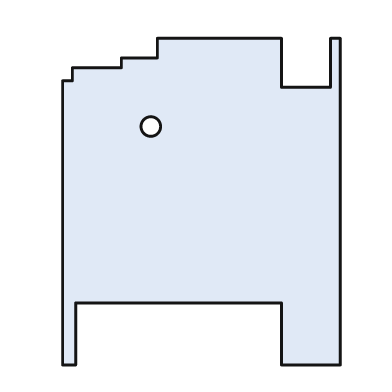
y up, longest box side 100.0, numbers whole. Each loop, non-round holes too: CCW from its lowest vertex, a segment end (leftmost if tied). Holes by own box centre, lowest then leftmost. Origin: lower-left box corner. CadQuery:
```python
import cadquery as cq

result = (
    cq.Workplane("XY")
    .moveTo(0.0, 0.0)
    .lineTo(4.0, 0.0)
    .lineTo(4.0, 19.0)
    .lineTo(67.0, 19.0)
    .lineTo(67.0, 0.0)
    .lineTo(85.0, 0.0)
    .lineTo(85.0, 100.0)
    .lineTo(82.0, 100.0)
    .lineTo(82.0, 85.0)
    .lineTo(67.0, 85.0)
    .lineTo(67.0, 100.0)
    .lineTo(29.0, 100.0)
    .lineTo(29.0, 94.0)
    .lineTo(18.0, 94.0)
    .lineTo(18.0, 91.0)
    .lineTo(3.0, 91.0)
    .lineTo(3.0, 87.0)
    .lineTo(0.0, 87.0)
    .close()
    .moveTo(27.0, 73.0)
    .circle(3.0)
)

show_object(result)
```